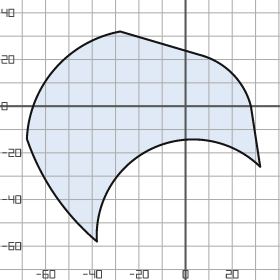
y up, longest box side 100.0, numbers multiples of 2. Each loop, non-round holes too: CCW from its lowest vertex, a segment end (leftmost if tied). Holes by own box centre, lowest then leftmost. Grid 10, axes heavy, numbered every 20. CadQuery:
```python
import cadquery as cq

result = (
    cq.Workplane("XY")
    .moveTo(-38.0, -58.0)
    .threePointArc((-14.0, -18.0), (32.0, -26.0))
    .lineTo(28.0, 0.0)
    .threePointArc((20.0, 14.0), (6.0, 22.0))
    .lineTo(-28.0, 32.0)
    .threePointArc((-56.0, 16.0), (-68.0, -14.0))
    .threePointArc((-56.0, -38.0), (-38.0, -58.0))
    .close()
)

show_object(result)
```